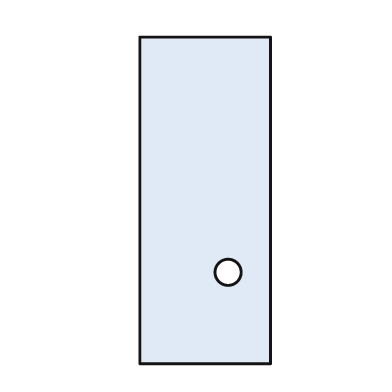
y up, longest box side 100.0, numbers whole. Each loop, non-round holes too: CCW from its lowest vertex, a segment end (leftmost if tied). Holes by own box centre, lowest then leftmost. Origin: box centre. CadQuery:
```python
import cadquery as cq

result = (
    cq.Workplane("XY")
    .moveTo(-20.0, -50.0)
    .lineTo(20.0, -50.0)
    .lineTo(20.0, 50.0)
    .lineTo(-20.0, 50.0)
    .close()
    .moveTo(7.0, -22.0)
    .circle(4.0)
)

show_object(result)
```